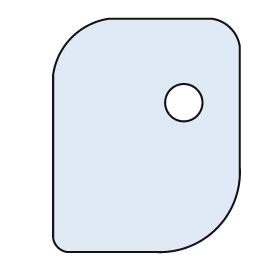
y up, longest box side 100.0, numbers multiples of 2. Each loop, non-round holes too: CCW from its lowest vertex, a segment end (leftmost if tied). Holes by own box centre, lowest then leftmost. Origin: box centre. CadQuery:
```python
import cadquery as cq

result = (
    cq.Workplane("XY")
    .moveTo(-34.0, -50.0)
    .lineTo(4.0, -50.0)
    .threePointArc((30.0, -40.0), (40.0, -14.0))
    .lineTo(40.0, 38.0)
    .threePointArc((36.0, 46.0), (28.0, 50.0))
    .lineTo(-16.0, 50.0)
    .threePointArc((-32.0, 42.0), (-40.0, 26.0))
    .lineTo(-40.0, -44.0)
    .threePointArc((-38.0, -48.0), (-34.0, -50.0))
    .close()
    .moveTo(16.0, 14.0)
    .circle(8.0)
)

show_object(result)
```